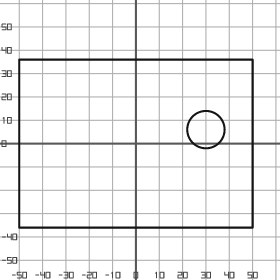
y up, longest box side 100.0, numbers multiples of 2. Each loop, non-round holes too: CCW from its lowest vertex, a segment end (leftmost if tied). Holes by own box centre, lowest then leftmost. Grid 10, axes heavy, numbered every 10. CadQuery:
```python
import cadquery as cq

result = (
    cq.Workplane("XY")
    .moveTo(-50.0, -36.0)
    .lineTo(50.0, -36.0)
    .lineTo(50.0, 36.0)
    .lineTo(-50.0, 36.0)
    .close()
    .moveTo(30.0, 6.0)
    .circle(8.0)
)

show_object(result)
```